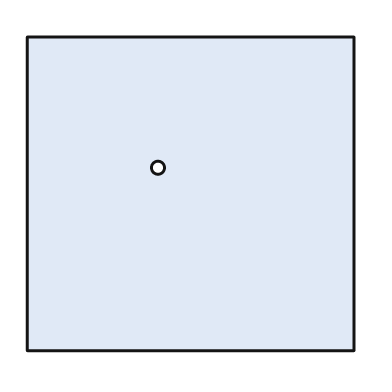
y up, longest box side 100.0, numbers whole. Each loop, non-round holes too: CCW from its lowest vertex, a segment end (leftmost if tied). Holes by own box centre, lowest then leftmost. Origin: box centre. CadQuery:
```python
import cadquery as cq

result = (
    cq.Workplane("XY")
    .moveTo(-50.0, -48.0)
    .lineTo(50.0, -48.0)
    .lineTo(50.0, 48.0)
    .lineTo(-50.0, 48.0)
    .close()
    .moveTo(-10.0, 8.0)
    .circle(2.0)
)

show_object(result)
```